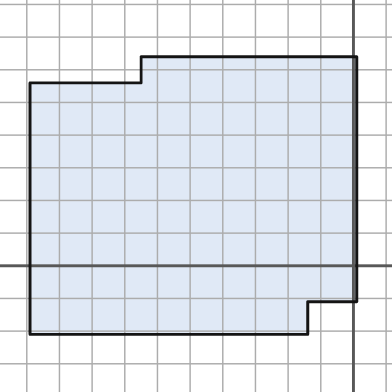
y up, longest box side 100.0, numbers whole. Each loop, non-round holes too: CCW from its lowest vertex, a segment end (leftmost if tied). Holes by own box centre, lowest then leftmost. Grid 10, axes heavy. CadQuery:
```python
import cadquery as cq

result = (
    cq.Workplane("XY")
    .moveTo(-99.0, -21.0)
    .lineTo(-14.0, -21.0)
    .lineTo(-14.0, -11.0)
    .lineTo(1.0, -11.0)
    .lineTo(1.0, 64.0)
    .lineTo(-65.0, 64.0)
    .lineTo(-65.0, 56.0)
    .lineTo(-99.0, 56.0)
    .close()
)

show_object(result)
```